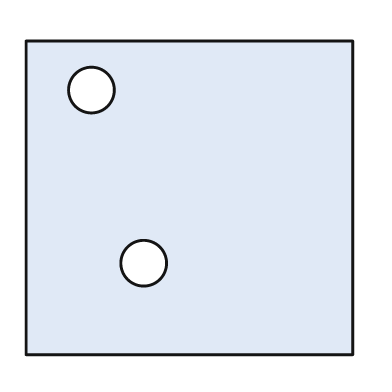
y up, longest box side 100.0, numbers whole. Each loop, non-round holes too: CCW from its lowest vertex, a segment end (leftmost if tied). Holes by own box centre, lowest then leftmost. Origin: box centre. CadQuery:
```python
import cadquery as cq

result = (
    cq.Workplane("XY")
    .moveTo(-50.0, -48.0)
    .lineTo(50.0, -48.0)
    .lineTo(50.0, 48.0)
    .lineTo(-50.0, 48.0)
    .close()
    .moveTo(-14.0, -20.0)
    .circle(7.0)
    .moveTo(-30.0, 33.0)
    .circle(7.0)
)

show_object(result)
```